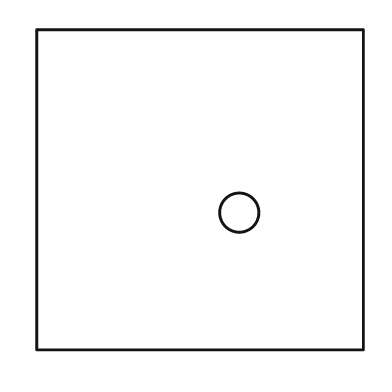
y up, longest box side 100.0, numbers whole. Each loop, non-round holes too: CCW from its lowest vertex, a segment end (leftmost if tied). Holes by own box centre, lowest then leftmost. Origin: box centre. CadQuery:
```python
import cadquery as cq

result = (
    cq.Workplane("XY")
    .moveTo(-50.0, -49.0)
    .lineTo(50.0, -49.0)
    .lineTo(50.0, 49.0)
    .lineTo(-50.0, 49.0)
    .close()
    .moveTo(12.0, -7.0)
    .circle(6.0)
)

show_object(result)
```